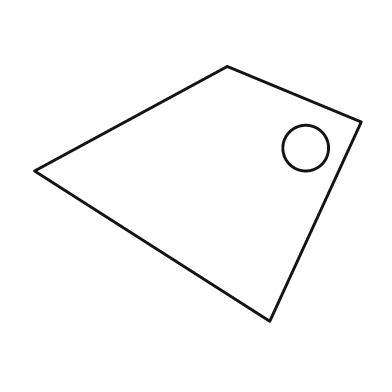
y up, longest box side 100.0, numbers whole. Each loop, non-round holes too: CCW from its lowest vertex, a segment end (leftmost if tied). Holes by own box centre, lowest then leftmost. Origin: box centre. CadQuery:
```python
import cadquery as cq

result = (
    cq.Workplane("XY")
    .moveTo(22.0, -39.0)
    .lineTo(50.0, 22.0)
    .lineTo(9.0, 39.0)
    .lineTo(-50.0, 7.0)
    .close()
    .moveTo(33.0, 14.0)
    .circle(7.0)
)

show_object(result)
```